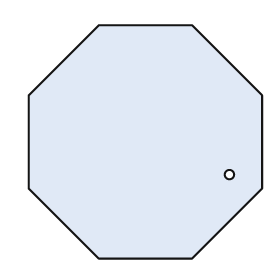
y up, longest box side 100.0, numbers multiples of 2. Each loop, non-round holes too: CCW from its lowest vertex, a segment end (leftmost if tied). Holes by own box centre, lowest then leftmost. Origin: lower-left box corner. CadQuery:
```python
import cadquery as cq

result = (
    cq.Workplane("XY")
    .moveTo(30.0, 0.0)
    .lineTo(70.0, 0.0)
    .lineTo(100.0, 30.0)
    .lineTo(100.0, 70.0)
    .lineTo(70.0, 100.0)
    .lineTo(30.0, 100.0)
    .lineTo(0.0, 70.0)
    .lineTo(0.0, 30.0)
    .close()
    .moveTo(86.0, 36.0)
    .circle(2.0)
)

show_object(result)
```